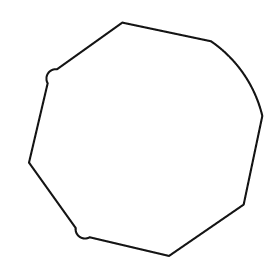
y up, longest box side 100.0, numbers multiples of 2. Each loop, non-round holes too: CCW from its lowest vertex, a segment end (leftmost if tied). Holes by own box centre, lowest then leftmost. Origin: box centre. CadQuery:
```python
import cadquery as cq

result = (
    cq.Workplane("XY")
    .moveTo(10.0, -50.0)
    .lineTo(42.0, -28.0)
    .lineTo(50.0, 10.0)
    .threePointArc((42.0, 28.0), (28.0, 42.0))
    .lineTo(-10.0, 50.0)
    .lineTo(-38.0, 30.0)
    .threePointArc((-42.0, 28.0), (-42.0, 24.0))
    .lineTo(-50.0, -10.0)
    .lineTo(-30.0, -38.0)
    .threePointArc((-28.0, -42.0), (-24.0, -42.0))
    .close()
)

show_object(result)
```